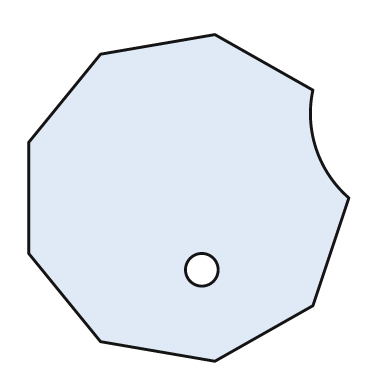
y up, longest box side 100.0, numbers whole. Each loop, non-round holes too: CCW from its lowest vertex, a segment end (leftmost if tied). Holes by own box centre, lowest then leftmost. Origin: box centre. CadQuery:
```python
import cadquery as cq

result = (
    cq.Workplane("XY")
    .moveTo(8.0, -50.0)
    .lineTo(38.0, -33.0)
    .lineTo(49.0, 0.0)
    .threePointArc((39.0, 15.0), (38.0, 33.0))
    .lineTo(8.0, 50.0)
    .lineTo(-27.0, 44.0)
    .lineTo(-49.0, 17.0)
    .lineTo(-49.0, -17.0)
    .lineTo(-27.0, -44.0)
    .close()
    .moveTo(4.0, -22.0)
    .circle(5.0)
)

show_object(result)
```